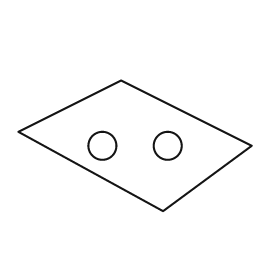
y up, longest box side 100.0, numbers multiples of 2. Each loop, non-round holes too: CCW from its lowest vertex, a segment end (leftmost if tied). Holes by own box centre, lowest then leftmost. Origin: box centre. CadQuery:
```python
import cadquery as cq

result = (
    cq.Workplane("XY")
    .moveTo(12.0, -28.0)
    .lineTo(50.0, 0.0)
    .lineTo(-6.0, 28.0)
    .lineTo(-50.0, 6.0)
    .close()
    .moveTo(-14.0, 0.0)
    .circle(6.0)
    .moveTo(14.0, 0.0)
    .circle(6.0)
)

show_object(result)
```